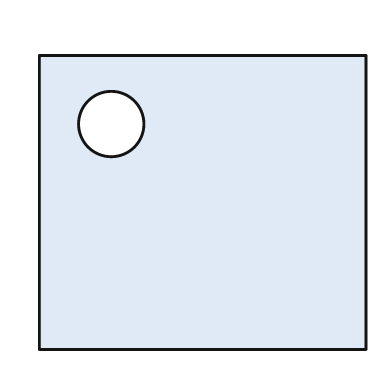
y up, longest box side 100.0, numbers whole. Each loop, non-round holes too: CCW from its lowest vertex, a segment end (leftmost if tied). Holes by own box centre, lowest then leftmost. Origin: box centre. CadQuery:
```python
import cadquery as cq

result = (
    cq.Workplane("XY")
    .moveTo(-50.0, -45.0)
    .lineTo(50.0, -45.0)
    .lineTo(50.0, 45.0)
    .lineTo(-50.0, 45.0)
    .close()
    .moveTo(-28.0, 24.0)
    .circle(10.0)
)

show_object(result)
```